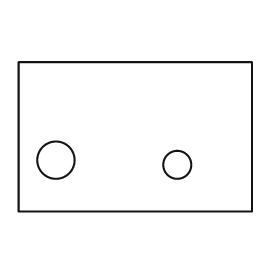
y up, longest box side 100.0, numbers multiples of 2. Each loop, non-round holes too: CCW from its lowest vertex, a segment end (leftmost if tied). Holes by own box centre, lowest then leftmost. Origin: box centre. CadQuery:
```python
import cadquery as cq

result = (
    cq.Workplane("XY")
    .moveTo(-50.0, -32.0)
    .lineTo(50.0, -32.0)
    .lineTo(50.0, 32.0)
    .lineTo(-50.0, 32.0)
    .close()
    .moveTo(18.0, -12.0)
    .circle(6.0)
    .moveTo(-34.0, -10.0)
    .circle(8.0)
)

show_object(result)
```